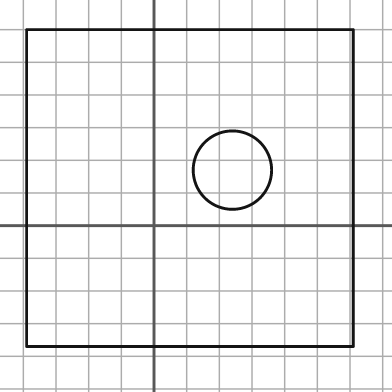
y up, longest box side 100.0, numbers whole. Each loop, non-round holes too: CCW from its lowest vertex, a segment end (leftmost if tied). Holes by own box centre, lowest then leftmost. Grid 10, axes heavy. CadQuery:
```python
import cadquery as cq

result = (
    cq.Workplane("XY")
    .moveTo(-39.0, -37.0)
    .lineTo(61.0, -37.0)
    .lineTo(61.0, 60.0)
    .lineTo(-39.0, 60.0)
    .close()
    .moveTo(24.0, 17.0)
    .circle(12.0)
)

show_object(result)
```